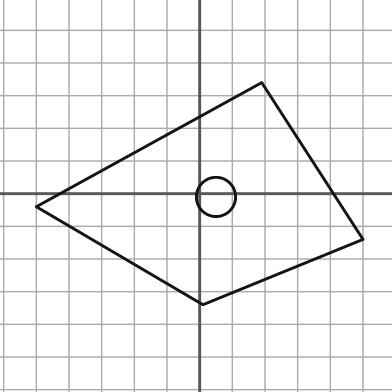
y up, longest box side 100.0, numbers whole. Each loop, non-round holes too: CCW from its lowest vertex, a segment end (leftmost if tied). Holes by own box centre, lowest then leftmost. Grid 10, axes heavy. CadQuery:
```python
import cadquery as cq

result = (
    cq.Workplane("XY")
    .moveTo(1.0, -34.0)
    .lineTo(50.0, -14.0)
    .lineTo(19.0, 34.0)
    .lineTo(-50.0, -4.0)
    .close()
    .moveTo(5.0, -1.0)
    .circle(6.0)
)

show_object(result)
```